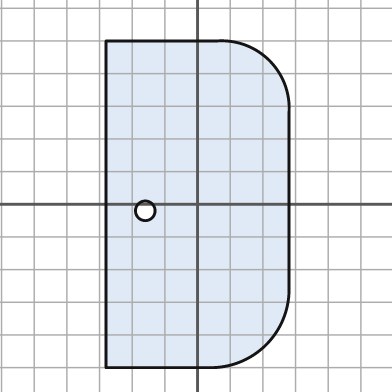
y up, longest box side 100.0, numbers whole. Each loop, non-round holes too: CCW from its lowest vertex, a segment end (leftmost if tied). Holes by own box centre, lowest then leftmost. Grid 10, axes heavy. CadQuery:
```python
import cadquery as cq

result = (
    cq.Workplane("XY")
    .moveTo(-28.0, -50.0)
    .lineTo(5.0, -50.0)
    .threePointArc((21.0, -43.0), (28.0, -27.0))
    .lineTo(28.0, 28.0)
    .threePointArc((22.0, 44.0), (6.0, 50.0))
    .lineTo(-28.0, 50.0)
    .close()
    .moveTo(-16.0, -2.0)
    .circle(3.0)
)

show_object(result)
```